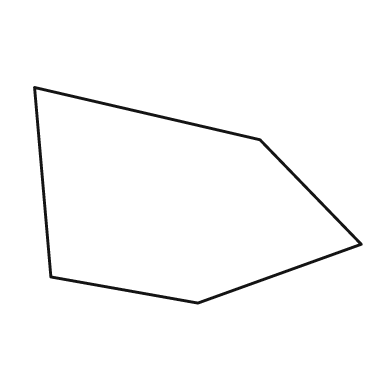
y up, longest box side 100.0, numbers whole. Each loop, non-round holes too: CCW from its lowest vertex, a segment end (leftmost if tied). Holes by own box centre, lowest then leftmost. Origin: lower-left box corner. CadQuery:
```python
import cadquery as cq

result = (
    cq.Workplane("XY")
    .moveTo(50.0, 0.0)
    .lineTo(100.0, 18.0)
    .lineTo(69.0, 50.0)
    .lineTo(0.0, 66.0)
    .lineTo(5.0, 8.0)
    .close()
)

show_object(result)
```